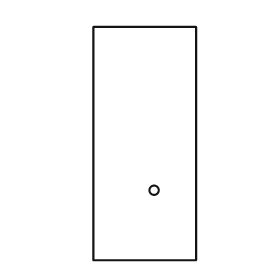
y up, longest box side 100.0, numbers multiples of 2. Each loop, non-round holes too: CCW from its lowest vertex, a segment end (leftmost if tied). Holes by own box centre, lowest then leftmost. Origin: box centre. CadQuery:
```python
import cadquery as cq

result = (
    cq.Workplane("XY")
    .moveTo(-22.0, -50.0)
    .lineTo(22.0, -50.0)
    .lineTo(22.0, 50.0)
    .lineTo(-22.0, 50.0)
    .close()
    .moveTo(4.0, -20.0)
    .circle(2.0)
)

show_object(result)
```